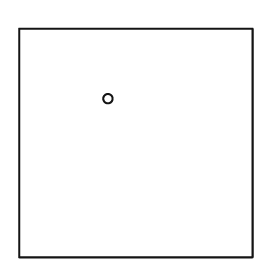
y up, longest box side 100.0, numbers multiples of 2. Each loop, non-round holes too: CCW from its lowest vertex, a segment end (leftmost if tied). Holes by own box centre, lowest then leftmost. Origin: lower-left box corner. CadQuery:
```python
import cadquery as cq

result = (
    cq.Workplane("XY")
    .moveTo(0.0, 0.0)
    .lineTo(100.0, 0.0)
    .lineTo(100.0, 98.0)
    .lineTo(0.0, 98.0)
    .close()
    .moveTo(38.0, 68.0)
    .circle(2.0)
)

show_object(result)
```